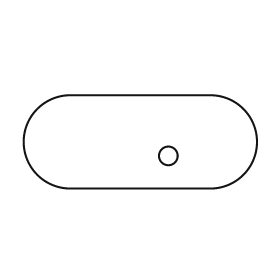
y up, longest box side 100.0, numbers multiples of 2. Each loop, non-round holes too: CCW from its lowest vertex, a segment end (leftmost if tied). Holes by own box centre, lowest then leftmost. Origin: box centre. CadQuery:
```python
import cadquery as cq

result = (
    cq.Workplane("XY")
    .moveTo(-30.0, -20.0)
    .lineTo(30.0, -20.0)
    .threePointArc((50.0, 0.0), (30.0, 20.0))
    .lineTo(-30.0, 20.0)
    .threePointArc((-50.0, 0.0), (-30.0, -20.0))
    .close()
    .moveTo(12.0, -6.0)
    .circle(4.0)
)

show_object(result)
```